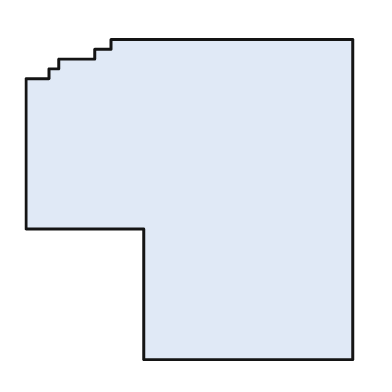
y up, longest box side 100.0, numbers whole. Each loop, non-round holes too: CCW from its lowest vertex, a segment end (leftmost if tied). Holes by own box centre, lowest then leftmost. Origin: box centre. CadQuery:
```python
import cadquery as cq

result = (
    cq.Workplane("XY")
    .moveTo(-14.0, -49.0)
    .lineTo(50.0, -49.0)
    .lineTo(50.0, 49.0)
    .lineTo(-24.0, 49.0)
    .lineTo(-24.0, 46.0)
    .lineTo(-29.0, 46.0)
    .lineTo(-29.0, 43.0)
    .lineTo(-40.0, 43.0)
    .lineTo(-40.0, 40.0)
    .lineTo(-43.0, 40.0)
    .lineTo(-43.0, 37.0)
    .lineTo(-50.0, 37.0)
    .lineTo(-50.0, -9.0)
    .lineTo(-14.0, -9.0)
    .close()
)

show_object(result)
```